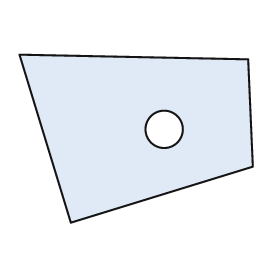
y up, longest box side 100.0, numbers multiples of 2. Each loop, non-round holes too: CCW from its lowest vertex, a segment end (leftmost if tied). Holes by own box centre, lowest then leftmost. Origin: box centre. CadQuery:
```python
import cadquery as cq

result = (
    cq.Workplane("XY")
    .moveTo(-28.0, -36.0)
    .lineTo(50.0, -12.0)
    .lineTo(48.0, 34.0)
    .lineTo(-50.0, 36.0)
    .close()
    .moveTo(12.0, 4.0)
    .circle(8.0)
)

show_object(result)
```